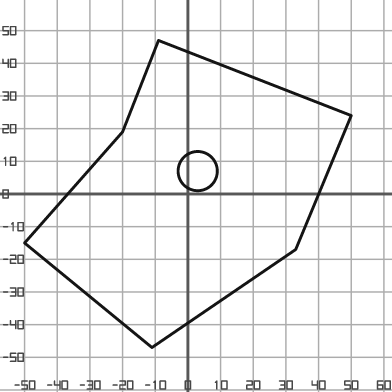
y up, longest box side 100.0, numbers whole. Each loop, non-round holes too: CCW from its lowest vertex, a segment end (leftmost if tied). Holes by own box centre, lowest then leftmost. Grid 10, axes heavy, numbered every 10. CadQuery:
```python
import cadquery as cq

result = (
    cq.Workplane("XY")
    .moveTo(-11.0, -47.0)
    .lineTo(33.0, -17.0)
    .lineTo(50.0, 24.0)
    .lineTo(-9.0, 47.0)
    .lineTo(-20.0, 19.0)
    .lineTo(-50.0, -15.0)
    .close()
    .moveTo(3.0, 7.0)
    .circle(6.0)
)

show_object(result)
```